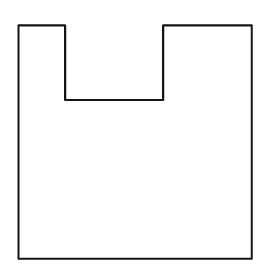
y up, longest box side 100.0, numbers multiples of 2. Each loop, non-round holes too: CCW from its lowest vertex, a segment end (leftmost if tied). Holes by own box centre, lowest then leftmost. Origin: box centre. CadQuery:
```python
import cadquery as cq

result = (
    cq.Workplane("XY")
    .moveTo(-50.0, -50.0)
    .lineTo(50.0, -50.0)
    .lineTo(50.0, 50.0)
    .lineTo(12.0, 50.0)
    .lineTo(12.0, 18.0)
    .lineTo(-30.0, 18.0)
    .lineTo(-30.0, 50.0)
    .lineTo(-50.0, 50.0)
    .close()
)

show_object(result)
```